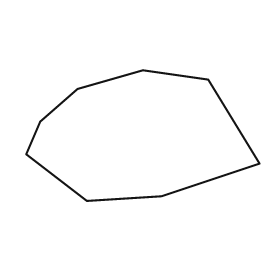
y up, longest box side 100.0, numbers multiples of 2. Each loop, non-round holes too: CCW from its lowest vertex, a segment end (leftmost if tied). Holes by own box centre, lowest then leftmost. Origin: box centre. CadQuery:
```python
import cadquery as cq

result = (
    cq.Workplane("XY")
    .moveTo(-24.0, -28.0)
    .lineTo(8.0, -26.0)
    .lineTo(50.0, -12.0)
    .lineTo(28.0, 24.0)
    .lineTo(0.0, 28.0)
    .lineTo(-28.0, 20.0)
    .lineTo(-44.0, 6.0)
    .lineTo(-50.0, -8.0)
    .close()
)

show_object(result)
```